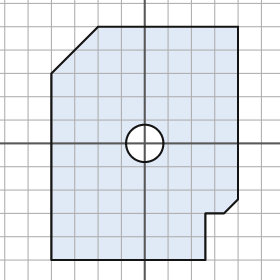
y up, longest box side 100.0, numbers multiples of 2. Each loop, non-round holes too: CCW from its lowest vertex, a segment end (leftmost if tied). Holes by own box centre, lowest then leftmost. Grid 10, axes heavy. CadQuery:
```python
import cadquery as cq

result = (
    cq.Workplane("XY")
    .moveTo(-40.0, -50.0)
    .lineTo(26.0, -50.0)
    .lineTo(26.0, -30.0)
    .lineTo(34.0, -30.0)
    .lineTo(40.0, -24.0)
    .lineTo(40.0, 50.0)
    .lineTo(-20.0, 50.0)
    .lineTo(-40.0, 30.0)
    .close()
    .moveTo(0.0, 0.0)
    .circle(8.0)
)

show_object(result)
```